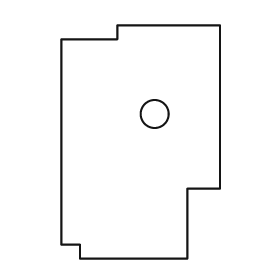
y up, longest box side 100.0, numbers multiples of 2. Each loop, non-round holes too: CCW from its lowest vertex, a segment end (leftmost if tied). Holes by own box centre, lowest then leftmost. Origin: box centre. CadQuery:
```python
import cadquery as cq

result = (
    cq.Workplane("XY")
    .moveTo(-26.0, -50.0)
    .lineTo(20.0, -50.0)
    .lineTo(20.0, -20.0)
    .lineTo(34.0, -20.0)
    .lineTo(34.0, 50.0)
    .lineTo(-10.0, 50.0)
    .lineTo(-10.0, 44.0)
    .lineTo(-34.0, 44.0)
    .lineTo(-34.0, -44.0)
    .lineTo(-26.0, -44.0)
    .close()
    .moveTo(6.0, 12.0)
    .circle(6.0)
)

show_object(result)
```